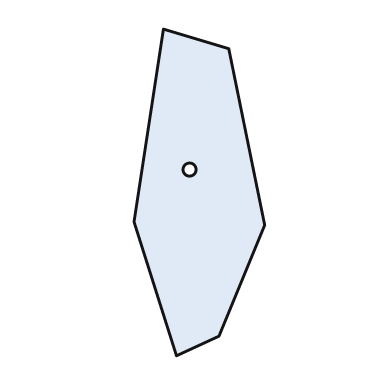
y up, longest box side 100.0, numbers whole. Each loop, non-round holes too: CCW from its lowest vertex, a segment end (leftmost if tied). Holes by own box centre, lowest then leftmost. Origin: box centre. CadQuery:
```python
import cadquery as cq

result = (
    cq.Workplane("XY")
    .moveTo(-7.0, -50.0)
    .lineTo(6.0, -44.0)
    .lineTo(20.0, -10.0)
    .lineTo(9.0, 44.0)
    .lineTo(-11.0, 50.0)
    .lineTo(-20.0, -9.0)
    .close()
    .moveTo(-3.0, 7.0)
    .circle(2.0)
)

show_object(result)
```